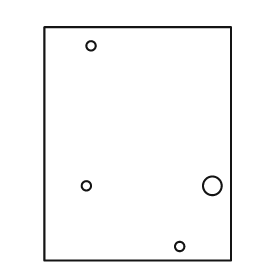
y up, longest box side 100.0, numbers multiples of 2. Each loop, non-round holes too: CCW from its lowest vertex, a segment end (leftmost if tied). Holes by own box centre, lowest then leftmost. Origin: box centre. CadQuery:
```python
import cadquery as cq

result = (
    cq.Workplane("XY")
    .moveTo(-40.0, -50.0)
    .lineTo(40.0, -50.0)
    .lineTo(40.0, 50.0)
    .lineTo(-40.0, 50.0)
    .close()
    .moveTo(18.0, -44.0)
    .circle(2.0)
    .moveTo(-22.0, -18.0)
    .circle(2.0)
    .moveTo(32.0, -18.0)
    .circle(4.0)
    .moveTo(-20.0, 42.0)
    .circle(2.0)
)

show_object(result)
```